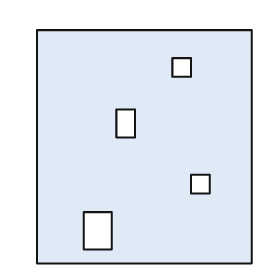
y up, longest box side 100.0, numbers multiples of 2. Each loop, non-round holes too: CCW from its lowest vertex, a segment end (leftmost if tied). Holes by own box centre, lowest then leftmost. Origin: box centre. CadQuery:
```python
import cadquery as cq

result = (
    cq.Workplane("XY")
    .moveTo(-46.0, -50.0)
    .lineTo(46.0, -50.0)
    .lineTo(46.0, 50.0)
    .lineTo(-46.0, 50.0)
    .close()
    .moveTo(-26.0, -44.0)
    .lineTo(-14.0, -44.0)
    .lineTo(-14.0, -28.0)
    .lineTo(-26.0, -28.0)
    .close()
    .moveTo(20.0, -20.0)
    .lineTo(28.0, -20.0)
    .lineTo(28.0, -12.0)
    .lineTo(20.0, -12.0)
    .close()
    .moveTo(-12.0, 4.0)
    .lineTo(-4.0, 4.0)
    .lineTo(-4.0, 16.0)
    .lineTo(-12.0, 16.0)
    .close()
    .moveTo(12.0, 30.0)
    .lineTo(20.0, 30.0)
    .lineTo(20.0, 38.0)
    .lineTo(12.0, 38.0)
    .close()
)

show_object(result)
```